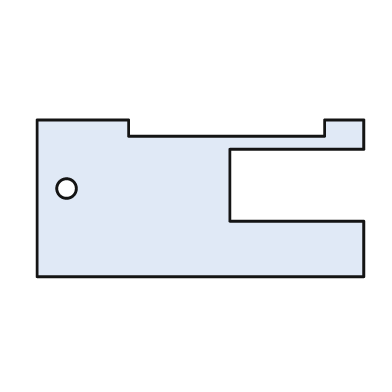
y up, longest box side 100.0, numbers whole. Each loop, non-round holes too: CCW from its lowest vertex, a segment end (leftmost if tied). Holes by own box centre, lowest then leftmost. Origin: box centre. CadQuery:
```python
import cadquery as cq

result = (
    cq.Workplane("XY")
    .moveTo(-50.0, -24.0)
    .lineTo(50.0, -24.0)
    .lineTo(50.0, -7.0)
    .lineTo(9.0, -7.0)
    .lineTo(9.0, 15.0)
    .lineTo(50.0, 15.0)
    .lineTo(50.0, 24.0)
    .lineTo(38.0, 24.0)
    .lineTo(38.0, 19.0)
    .lineTo(-22.0, 19.0)
    .lineTo(-22.0, 24.0)
    .lineTo(-50.0, 24.0)
    .close()
    .moveTo(-41.0, 3.0)
    .circle(3.0)
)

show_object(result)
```